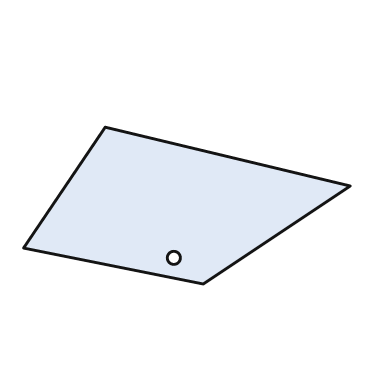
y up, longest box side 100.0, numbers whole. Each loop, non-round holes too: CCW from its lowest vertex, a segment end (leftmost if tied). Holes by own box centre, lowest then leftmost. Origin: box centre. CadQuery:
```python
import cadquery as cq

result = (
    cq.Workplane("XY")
    .moveTo(5.0, -24.0)
    .lineTo(50.0, 6.0)
    .lineTo(-25.0, 24.0)
    .lineTo(-50.0, -13.0)
    .close()
    .moveTo(-4.0, -16.0)
    .circle(2.0)
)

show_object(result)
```